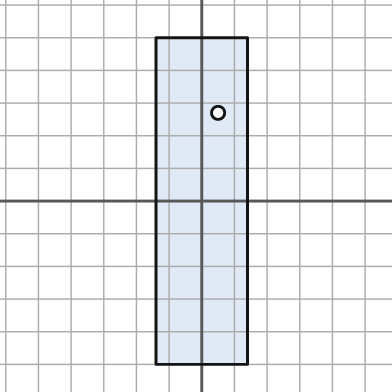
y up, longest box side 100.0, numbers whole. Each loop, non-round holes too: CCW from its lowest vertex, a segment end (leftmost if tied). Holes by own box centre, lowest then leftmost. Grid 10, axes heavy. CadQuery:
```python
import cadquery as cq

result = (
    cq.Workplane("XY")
    .moveTo(-14.0, -50.0)
    .lineTo(14.0, -50.0)
    .lineTo(14.0, 50.0)
    .lineTo(-14.0, 50.0)
    .close()
    .moveTo(5.0, 27.0)
    .circle(2.0)
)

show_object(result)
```